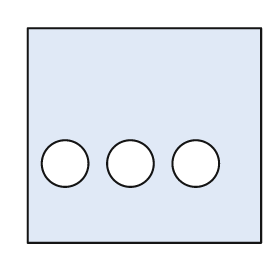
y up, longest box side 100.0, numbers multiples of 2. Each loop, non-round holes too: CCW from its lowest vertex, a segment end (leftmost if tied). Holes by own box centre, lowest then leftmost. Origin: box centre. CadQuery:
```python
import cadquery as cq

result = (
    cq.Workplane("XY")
    .moveTo(-50.0, -46.0)
    .lineTo(50.0, -46.0)
    .lineTo(50.0, 46.0)
    .lineTo(-50.0, 46.0)
    .close()
    .moveTo(-34.0, -12.0)
    .circle(10.0)
    .moveTo(-6.0, -12.0)
    .circle(10.0)
    .moveTo(22.0, -12.0)
    .circle(10.0)
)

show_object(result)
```